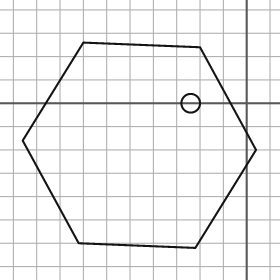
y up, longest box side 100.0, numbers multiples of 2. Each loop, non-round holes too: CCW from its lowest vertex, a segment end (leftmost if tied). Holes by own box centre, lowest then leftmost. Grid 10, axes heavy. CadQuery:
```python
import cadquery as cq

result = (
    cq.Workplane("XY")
    .moveTo(-22.0, -62.0)
    .lineTo(4.0, -20.0)
    .lineTo(-20.0, 24.0)
    .lineTo(-70.0, 26.0)
    .lineTo(-96.0, -16.0)
    .lineTo(-72.0, -60.0)
    .close()
    .moveTo(-24.0, 0.0)
    .circle(4.0)
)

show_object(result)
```